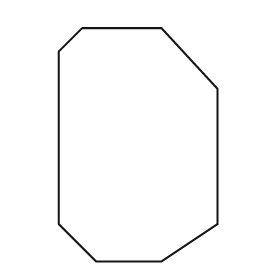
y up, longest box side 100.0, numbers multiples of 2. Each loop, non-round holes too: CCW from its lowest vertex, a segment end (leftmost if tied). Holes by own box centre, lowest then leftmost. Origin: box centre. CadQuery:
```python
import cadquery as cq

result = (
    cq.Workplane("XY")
    .moveTo(-18.0, -50.0)
    .lineTo(10.0, -50.0)
    .lineTo(34.0, -34.0)
    .lineTo(34.0, 24.0)
    .lineTo(10.0, 50.0)
    .lineTo(-24.0, 50.0)
    .lineTo(-34.0, 40.0)
    .lineTo(-34.0, -34.0)
    .close()
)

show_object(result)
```